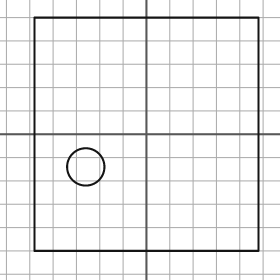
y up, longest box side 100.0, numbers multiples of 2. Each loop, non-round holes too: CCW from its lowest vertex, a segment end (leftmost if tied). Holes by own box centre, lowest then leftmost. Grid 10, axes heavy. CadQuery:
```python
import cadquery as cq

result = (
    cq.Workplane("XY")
    .moveTo(-48.0, -50.0)
    .lineTo(48.0, -50.0)
    .lineTo(48.0, 50.0)
    .lineTo(-48.0, 50.0)
    .close()
    .moveTo(-26.0, -14.0)
    .circle(8.0)
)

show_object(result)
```